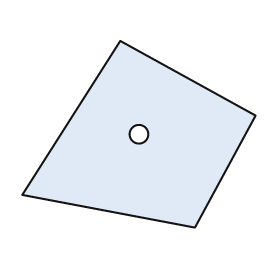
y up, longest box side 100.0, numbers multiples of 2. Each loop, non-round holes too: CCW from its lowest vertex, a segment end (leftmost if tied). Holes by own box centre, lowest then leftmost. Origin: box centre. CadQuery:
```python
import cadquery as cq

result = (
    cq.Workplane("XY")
    .moveTo(24.0, -40.0)
    .lineTo(50.0, 8.0)
    .lineTo(-8.0, 40.0)
    .lineTo(-50.0, -26.0)
    .close()
    .moveTo(0.0, 0.0)
    .circle(4.0)
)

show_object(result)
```